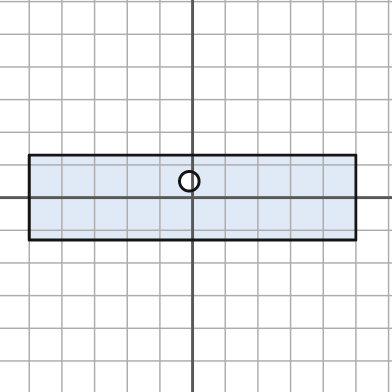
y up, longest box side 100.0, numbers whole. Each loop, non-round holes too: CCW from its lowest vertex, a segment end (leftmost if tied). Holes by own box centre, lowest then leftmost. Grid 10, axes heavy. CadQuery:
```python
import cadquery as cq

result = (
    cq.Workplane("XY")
    .moveTo(-50.0, -13.0)
    .lineTo(50.0, -13.0)
    .lineTo(50.0, 13.0)
    .lineTo(-50.0, 13.0)
    .close()
    .moveTo(-1.0, 5.0)
    .circle(3.0)
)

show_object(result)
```